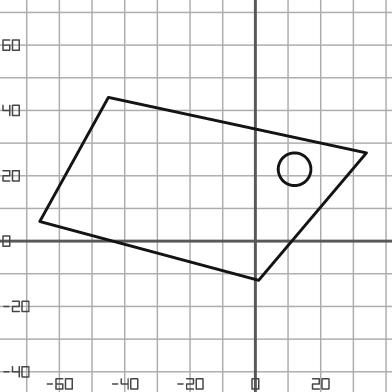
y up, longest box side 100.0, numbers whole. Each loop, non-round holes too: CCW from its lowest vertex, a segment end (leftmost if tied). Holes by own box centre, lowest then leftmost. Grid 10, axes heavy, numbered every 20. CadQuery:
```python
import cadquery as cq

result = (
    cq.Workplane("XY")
    .moveTo(1.0, -12.0)
    .lineTo(34.0, 27.0)
    .lineTo(-45.0, 44.0)
    .lineTo(-66.0, 6.0)
    .close()
    .moveTo(12.0, 22.0)
    .circle(5.0)
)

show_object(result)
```